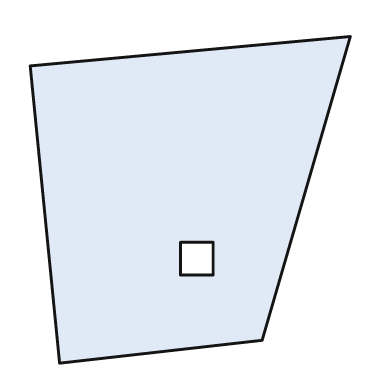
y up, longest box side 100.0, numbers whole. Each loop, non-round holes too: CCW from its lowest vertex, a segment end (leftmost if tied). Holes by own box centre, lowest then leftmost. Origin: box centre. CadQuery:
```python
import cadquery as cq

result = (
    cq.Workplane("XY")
    .moveTo(-40.0, -50.0)
    .lineTo(22.0, -43.0)
    .lineTo(49.0, 50.0)
    .lineTo(-49.0, 41.0)
    .close()
    .moveTo(-3.0, -23.0)
    .lineTo(7.0, -23.0)
    .lineTo(7.0, -13.0)
    .lineTo(-3.0, -13.0)
    .close()
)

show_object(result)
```